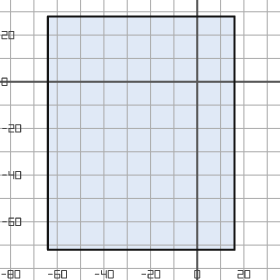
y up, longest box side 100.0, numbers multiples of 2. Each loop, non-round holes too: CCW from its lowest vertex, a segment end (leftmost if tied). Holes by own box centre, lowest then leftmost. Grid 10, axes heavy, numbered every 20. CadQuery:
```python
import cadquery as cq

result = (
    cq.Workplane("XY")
    .moveTo(-64.0, -72.0)
    .lineTo(16.0, -72.0)
    .lineTo(16.0, 28.0)
    .lineTo(-64.0, 28.0)
    .close()
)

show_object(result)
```